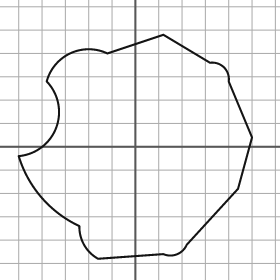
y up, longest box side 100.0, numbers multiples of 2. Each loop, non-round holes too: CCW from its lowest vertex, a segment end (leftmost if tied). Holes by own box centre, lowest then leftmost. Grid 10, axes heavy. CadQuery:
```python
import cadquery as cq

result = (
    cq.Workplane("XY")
    .moveTo(-16.0, -48.0)
    .lineTo(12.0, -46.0)
    .threePointArc((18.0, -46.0), (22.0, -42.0))
    .lineTo(44.0, -18.0)
    .lineTo(50.0, 4.0)
    .lineTo(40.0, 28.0)
    .threePointArc((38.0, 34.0), (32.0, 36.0))
    .lineTo(12.0, 48.0)
    .lineTo(-12.0, 40.0)
    .threePointArc((-28.0, 40.0), (-38.0, 28.0))
    .threePointArc((-34.0, 8.0), (-50.0, -4.0))
    .threePointArc((-40.0, -22.0), (-24.0, -34.0))
    .threePointArc((-22.0, -42.0), (-16.0, -48.0))
    .close()
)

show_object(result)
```